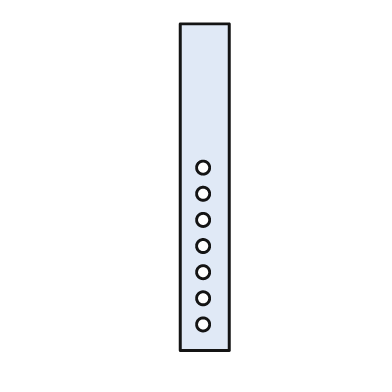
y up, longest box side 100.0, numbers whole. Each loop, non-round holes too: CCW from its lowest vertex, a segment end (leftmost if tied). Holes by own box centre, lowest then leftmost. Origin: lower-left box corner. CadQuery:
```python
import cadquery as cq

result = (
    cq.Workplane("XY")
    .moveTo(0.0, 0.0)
    .lineTo(15.0, 0.0)
    .lineTo(15.0, 100.0)
    .lineTo(0.0, 100.0)
    .close()
    .moveTo(7.0, 8.0)
    .circle(2.0)
    .moveTo(7.0, 16.0)
    .circle(2.0)
    .moveTo(7.0, 24.0)
    .circle(2.0)
    .moveTo(7.0, 32.0)
    .circle(2.0)
    .moveTo(7.0, 40.0)
    .circle(2.0)
    .moveTo(7.0, 48.0)
    .circle(2.0)
    .moveTo(7.0, 56.0)
    .circle(2.0)
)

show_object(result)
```